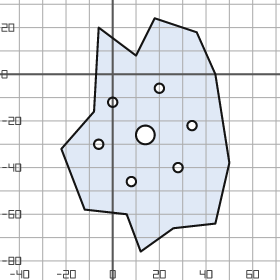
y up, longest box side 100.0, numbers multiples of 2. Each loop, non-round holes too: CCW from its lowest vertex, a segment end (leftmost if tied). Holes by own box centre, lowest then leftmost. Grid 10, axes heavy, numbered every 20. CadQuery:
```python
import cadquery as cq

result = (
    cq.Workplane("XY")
    .moveTo(12.0, -76.0)
    .lineTo(26.0, -66.0)
    .lineTo(44.0, -64.0)
    .lineTo(50.0, -38.0)
    .lineTo(44.0, 0.0)
    .lineTo(36.0, 18.0)
    .lineTo(18.0, 24.0)
    .lineTo(10.0, 8.0)
    .lineTo(-6.0, 20.0)
    .lineTo(-8.0, -16.0)
    .lineTo(-22.0, -32.0)
    .lineTo(-12.0, -58.0)
    .lineTo(6.0, -60.0)
    .close()
    .moveTo(8.0, -46.0)
    .circle(2.0)
    .moveTo(28.0, -40.0)
    .circle(2.0)
    .moveTo(-6.0, -30.0)
    .circle(2.0)
    .moveTo(14.0, -26.0)
    .circle(4.0)
    .moveTo(34.0, -22.0)
    .circle(2.0)
    .moveTo(0.0, -12.0)
    .circle(2.0)
    .moveTo(20.0, -6.0)
    .circle(2.0)
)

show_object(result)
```